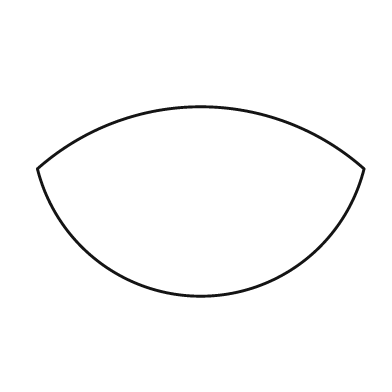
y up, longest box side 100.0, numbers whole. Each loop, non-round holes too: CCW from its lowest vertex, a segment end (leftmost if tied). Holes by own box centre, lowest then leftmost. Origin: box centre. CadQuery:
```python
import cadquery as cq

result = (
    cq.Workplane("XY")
    .moveTo(-50.0, 10.0)
    .threePointArc((0.0, -29.0), (50.0, 10.0))
    .threePointArc((0.0, 29.0), (-50.0, 10.0))
    .close()
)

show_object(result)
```